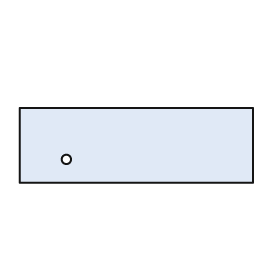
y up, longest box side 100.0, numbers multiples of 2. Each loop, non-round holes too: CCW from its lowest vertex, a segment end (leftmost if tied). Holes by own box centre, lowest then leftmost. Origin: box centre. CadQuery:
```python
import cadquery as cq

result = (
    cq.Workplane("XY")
    .moveTo(-50.0, -16.0)
    .lineTo(50.0, -16.0)
    .lineTo(50.0, 16.0)
    .lineTo(-50.0, 16.0)
    .close()
    .moveTo(-30.0, -6.0)
    .circle(2.0)
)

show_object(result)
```